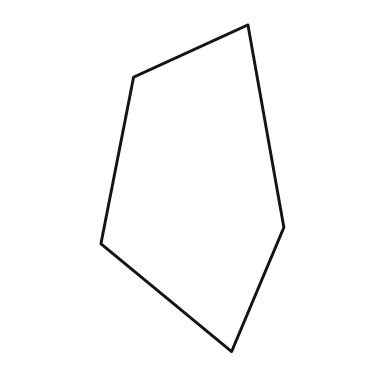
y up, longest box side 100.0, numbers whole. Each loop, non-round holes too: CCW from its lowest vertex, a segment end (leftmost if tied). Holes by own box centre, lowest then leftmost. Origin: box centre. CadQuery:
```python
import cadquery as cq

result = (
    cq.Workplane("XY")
    .moveTo(12.0, -50.0)
    .lineTo(28.0, -12.0)
    .lineTo(17.0, 50.0)
    .lineTo(-18.0, 34.0)
    .lineTo(-28.0, -17.0)
    .close()
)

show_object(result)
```